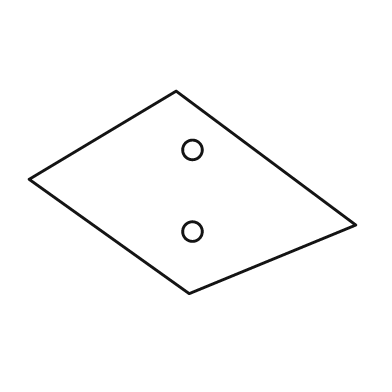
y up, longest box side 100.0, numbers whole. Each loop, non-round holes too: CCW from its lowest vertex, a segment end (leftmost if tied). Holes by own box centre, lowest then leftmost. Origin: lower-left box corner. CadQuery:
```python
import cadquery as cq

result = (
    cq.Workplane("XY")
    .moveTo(49.0, 0.0)
    .lineTo(100.0, 21.0)
    .lineTo(45.0, 62.0)
    .lineTo(0.0, 35.0)
    .close()
    .moveTo(50.0, 19.0)
    .circle(3.0)
    .moveTo(50.0, 44.0)
    .circle(3.0)
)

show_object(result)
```